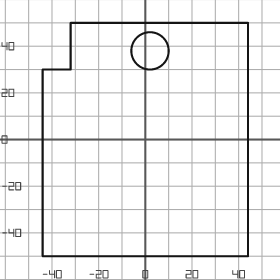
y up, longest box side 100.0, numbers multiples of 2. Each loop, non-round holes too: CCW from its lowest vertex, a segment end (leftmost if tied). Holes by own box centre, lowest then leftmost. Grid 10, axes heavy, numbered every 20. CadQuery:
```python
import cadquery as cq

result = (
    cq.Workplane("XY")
    .moveTo(-44.0, -50.0)
    .lineTo(44.0, -50.0)
    .lineTo(44.0, 50.0)
    .lineTo(-32.0, 50.0)
    .lineTo(-32.0, 30.0)
    .lineTo(-44.0, 30.0)
    .close()
    .moveTo(2.0, 38.0)
    .circle(8.0)
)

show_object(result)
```